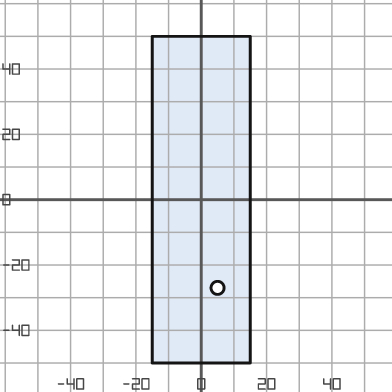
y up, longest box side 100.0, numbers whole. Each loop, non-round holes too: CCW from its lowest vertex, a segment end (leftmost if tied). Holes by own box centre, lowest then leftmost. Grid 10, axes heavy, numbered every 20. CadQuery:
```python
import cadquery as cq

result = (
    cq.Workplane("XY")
    .moveTo(-15.0, -50.0)
    .lineTo(15.0, -50.0)
    .lineTo(15.0, 50.0)
    .lineTo(-15.0, 50.0)
    .close()
    .moveTo(5.0, -27.0)
    .circle(2.0)
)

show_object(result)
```